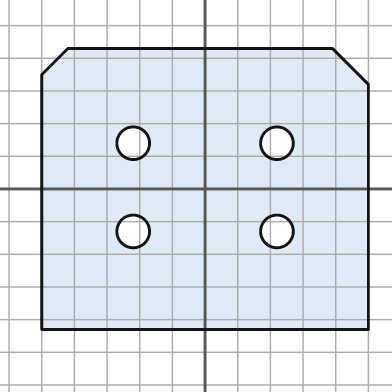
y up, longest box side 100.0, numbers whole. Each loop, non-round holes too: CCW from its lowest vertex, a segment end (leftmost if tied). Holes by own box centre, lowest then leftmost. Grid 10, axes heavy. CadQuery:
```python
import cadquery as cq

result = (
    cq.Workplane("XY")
    .moveTo(-50.0, -43.0)
    .lineTo(50.0, -43.0)
    .lineTo(50.0, 32.0)
    .lineTo(39.0, 43.0)
    .lineTo(-42.0, 43.0)
    .lineTo(-50.0, 35.0)
    .close()
    .moveTo(-22.0, -13.0)
    .circle(5.0)
    .moveTo(22.0, -13.0)
    .circle(5.0)
    .moveTo(-22.0, 14.0)
    .circle(5.0)
    .moveTo(22.0, 14.0)
    .circle(5.0)
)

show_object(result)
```